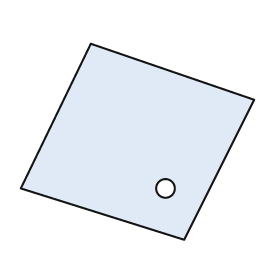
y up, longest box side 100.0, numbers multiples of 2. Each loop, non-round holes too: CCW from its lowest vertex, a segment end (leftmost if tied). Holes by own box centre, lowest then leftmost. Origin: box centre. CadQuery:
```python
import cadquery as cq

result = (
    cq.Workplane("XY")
    .moveTo(20.0, -42.0)
    .lineTo(50.0, 18.0)
    .lineTo(-20.0, 42.0)
    .lineTo(-50.0, -20.0)
    .close()
    .moveTo(12.0, -20.0)
    .circle(4.0)
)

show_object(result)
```